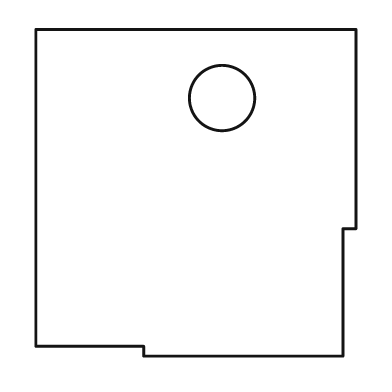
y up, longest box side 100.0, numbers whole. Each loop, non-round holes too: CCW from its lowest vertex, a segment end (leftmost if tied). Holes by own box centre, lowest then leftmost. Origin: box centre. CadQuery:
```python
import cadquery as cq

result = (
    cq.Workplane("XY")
    .moveTo(-16.0, -50.0)
    .lineTo(45.0, -50.0)
    .lineTo(45.0, -11.0)
    .lineTo(49.0, -11.0)
    .lineTo(49.0, 50.0)
    .lineTo(-49.0, 50.0)
    .lineTo(-49.0, -47.0)
    .lineTo(-16.0, -47.0)
    .close()
    .moveTo(8.0, 29.0)
    .circle(10.0)
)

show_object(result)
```